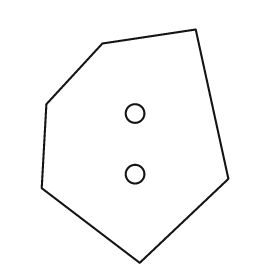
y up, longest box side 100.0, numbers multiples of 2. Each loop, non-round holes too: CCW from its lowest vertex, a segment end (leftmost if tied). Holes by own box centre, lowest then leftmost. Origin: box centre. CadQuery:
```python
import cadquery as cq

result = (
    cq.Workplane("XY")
    .moveTo(2.0, -50.0)
    .lineTo(40.0, -14.0)
    .lineTo(26.0, 50.0)
    .lineTo(-14.0, 44.0)
    .lineTo(-38.0, 18.0)
    .lineTo(-40.0, -18.0)
    .close()
    .moveTo(0.0, -12.0)
    .circle(4.0)
    .moveTo(0.0, 14.0)
    .circle(4.0)
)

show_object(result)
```